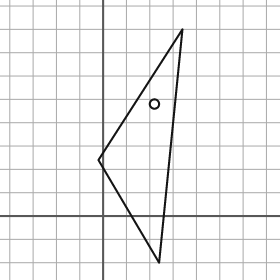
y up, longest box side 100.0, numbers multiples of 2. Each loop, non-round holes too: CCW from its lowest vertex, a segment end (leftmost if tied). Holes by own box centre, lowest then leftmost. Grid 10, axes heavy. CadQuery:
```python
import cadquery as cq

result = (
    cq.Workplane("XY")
    .moveTo(24.0, -20.0)
    .lineTo(34.0, 80.0)
    .lineTo(-2.0, 24.0)
    .close()
    .moveTo(22.0, 48.0)
    .circle(2.0)
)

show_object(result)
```